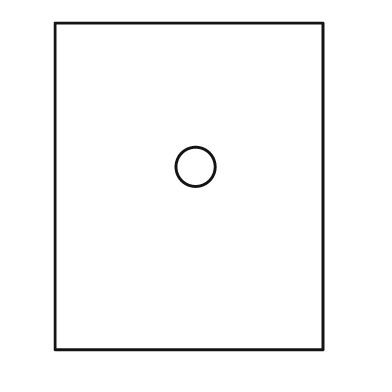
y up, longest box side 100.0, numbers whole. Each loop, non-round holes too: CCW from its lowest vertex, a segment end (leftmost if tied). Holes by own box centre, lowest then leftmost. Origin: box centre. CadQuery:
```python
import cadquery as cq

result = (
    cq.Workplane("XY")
    .moveTo(-41.0, -50.0)
    .lineTo(41.0, -50.0)
    .lineTo(41.0, 50.0)
    .lineTo(-41.0, 50.0)
    .close()
    .moveTo(2.0, 6.0)
    .circle(6.0)
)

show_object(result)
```